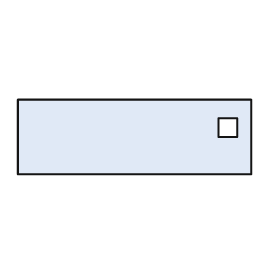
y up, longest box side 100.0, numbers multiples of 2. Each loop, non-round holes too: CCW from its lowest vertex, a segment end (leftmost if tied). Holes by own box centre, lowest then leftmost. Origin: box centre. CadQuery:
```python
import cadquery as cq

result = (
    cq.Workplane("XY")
    .moveTo(-50.0, -16.0)
    .lineTo(50.0, -16.0)
    .lineTo(50.0, 16.0)
    .lineTo(-50.0, 16.0)
    .close()
    .moveTo(36.0, 0.0)
    .lineTo(44.0, 0.0)
    .lineTo(44.0, 8.0)
    .lineTo(36.0, 8.0)
    .close()
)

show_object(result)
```